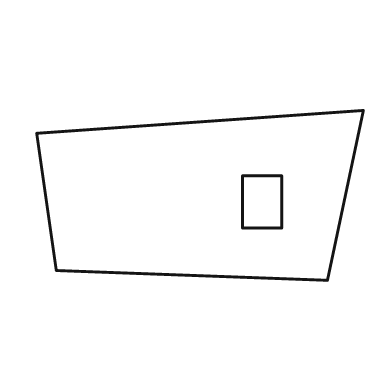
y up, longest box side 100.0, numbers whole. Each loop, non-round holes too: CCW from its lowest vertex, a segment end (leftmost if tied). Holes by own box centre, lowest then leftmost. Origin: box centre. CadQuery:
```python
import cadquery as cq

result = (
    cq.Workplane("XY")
    .moveTo(39.0, -26.0)
    .lineTo(50.0, 26.0)
    .lineTo(-50.0, 19.0)
    .lineTo(-44.0, -23.0)
    .close()
    .moveTo(13.0, -10.0)
    .lineTo(25.0, -10.0)
    .lineTo(25.0, 6.0)
    .lineTo(13.0, 6.0)
    .close()
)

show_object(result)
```